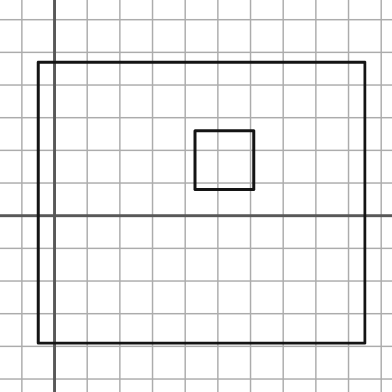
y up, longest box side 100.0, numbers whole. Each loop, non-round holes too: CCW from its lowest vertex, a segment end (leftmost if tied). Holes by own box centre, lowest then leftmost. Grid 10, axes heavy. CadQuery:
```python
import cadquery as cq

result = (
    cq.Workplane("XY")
    .moveTo(-5.0, -39.0)
    .lineTo(95.0, -39.0)
    .lineTo(95.0, 47.0)
    .lineTo(-5.0, 47.0)
    .close()
    .moveTo(43.0, 8.0)
    .lineTo(61.0, 8.0)
    .lineTo(61.0, 26.0)
    .lineTo(43.0, 26.0)
    .close()
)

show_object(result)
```